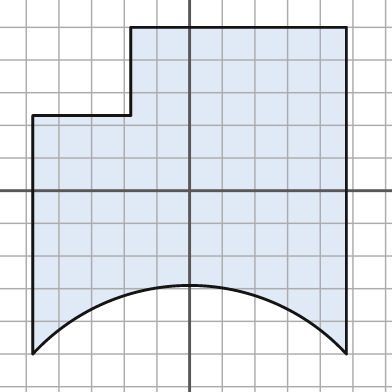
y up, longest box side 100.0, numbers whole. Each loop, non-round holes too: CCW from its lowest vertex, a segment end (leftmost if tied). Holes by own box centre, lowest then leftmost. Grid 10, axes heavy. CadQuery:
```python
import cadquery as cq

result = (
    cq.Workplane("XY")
    .moveTo(-48.0, -50.0)
    .threePointArc((0.0, -29.0), (48.0, -50.0))
    .lineTo(48.0, 50.0)
    .lineTo(-18.0, 50.0)
    .lineTo(-18.0, 23.0)
    .lineTo(-48.0, 23.0)
    .close()
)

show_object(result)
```